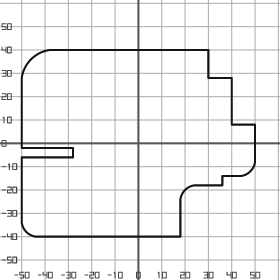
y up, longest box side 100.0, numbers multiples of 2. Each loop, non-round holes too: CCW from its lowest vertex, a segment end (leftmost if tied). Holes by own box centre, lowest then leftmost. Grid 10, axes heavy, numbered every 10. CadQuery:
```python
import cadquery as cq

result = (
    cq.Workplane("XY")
    .moveTo(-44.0, -40.0)
    .lineTo(18.0, -40.0)
    .lineTo(18.0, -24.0)
    .threePointArc((20.0, -20.0), (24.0, -18.0))
    .lineTo(36.0, -18.0)
    .lineTo(36.0, -14.0)
    .lineTo(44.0, -14.0)
    .threePointArc((48.0, -12.0), (50.0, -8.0))
    .lineTo(50.0, 8.0)
    .lineTo(40.0, 8.0)
    .lineTo(40.0, 28.0)
    .lineTo(30.0, 28.0)
    .lineTo(30.0, 40.0)
    .lineTo(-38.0, 40.0)
    .threePointArc((-46.0, 36.0), (-50.0, 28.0))
    .lineTo(-50.0, -2.0)
    .lineTo(-28.0, -2.0)
    .lineTo(-28.0, -6.0)
    .lineTo(-50.0, -6.0)
    .lineTo(-50.0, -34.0)
    .threePointArc((-48.0, -38.0), (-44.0, -40.0))
    .close()
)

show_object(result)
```